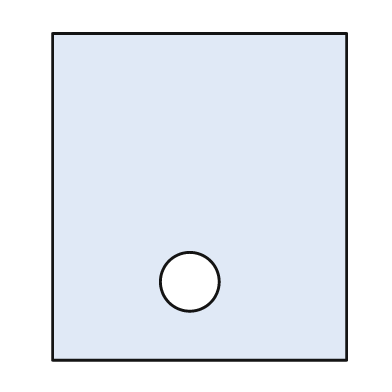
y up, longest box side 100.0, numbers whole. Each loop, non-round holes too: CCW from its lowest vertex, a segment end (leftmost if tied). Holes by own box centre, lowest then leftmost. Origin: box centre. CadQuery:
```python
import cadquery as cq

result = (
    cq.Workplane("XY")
    .moveTo(-45.0, -50.0)
    .lineTo(45.0, -50.0)
    .lineTo(45.0, 50.0)
    .lineTo(-45.0, 50.0)
    .close()
    .moveTo(-3.0, -26.0)
    .circle(9.0)
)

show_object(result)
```